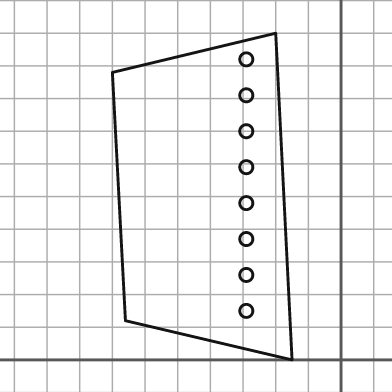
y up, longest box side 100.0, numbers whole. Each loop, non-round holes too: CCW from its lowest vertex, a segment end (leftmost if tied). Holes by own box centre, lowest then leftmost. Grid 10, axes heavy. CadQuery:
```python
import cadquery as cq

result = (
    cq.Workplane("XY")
    .moveTo(-15.0, 0.0)
    .lineTo(-20.0, 100.0)
    .lineTo(-70.0, 88.0)
    .lineTo(-66.0, 12.0)
    .close()
    .moveTo(-29.0, 15.0)
    .circle(2.0)
    .moveTo(-29.0, 26.0)
    .circle(2.0)
    .moveTo(-29.0, 37.0)
    .circle(2.0)
    .moveTo(-29.0, 48.0)
    .circle(2.0)
    .moveTo(-29.0, 59.0)
    .circle(2.0)
    .moveTo(-29.0, 70.0)
    .circle(2.0)
    .moveTo(-29.0, 81.0)
    .circle(2.0)
    .moveTo(-29.0, 92.0)
    .circle(2.0)
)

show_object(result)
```